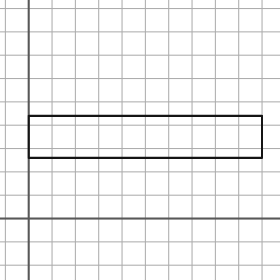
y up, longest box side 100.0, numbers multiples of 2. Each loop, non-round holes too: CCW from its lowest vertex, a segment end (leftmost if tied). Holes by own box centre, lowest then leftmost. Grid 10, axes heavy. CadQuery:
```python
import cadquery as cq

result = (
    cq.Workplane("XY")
    .moveTo(0.0, 26.0)
    .lineTo(100.0, 26.0)
    .lineTo(100.0, 44.0)
    .lineTo(0.0, 44.0)
    .close()
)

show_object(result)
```